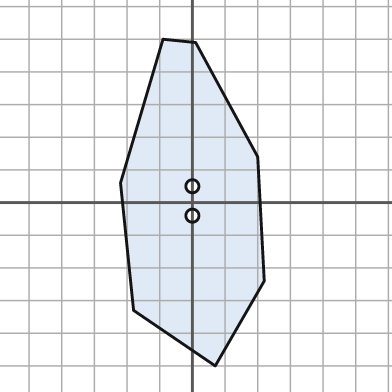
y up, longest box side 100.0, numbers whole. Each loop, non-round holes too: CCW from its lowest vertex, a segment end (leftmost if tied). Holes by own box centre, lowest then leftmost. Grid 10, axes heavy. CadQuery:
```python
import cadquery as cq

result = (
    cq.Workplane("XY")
    .moveTo(7.0, -50.0)
    .lineTo(22.0, -24.0)
    .lineTo(20.0, 14.0)
    .lineTo(1.0, 49.0)
    .lineTo(-9.0, 50.0)
    .lineTo(-22.0, 6.0)
    .lineTo(-18.0, -33.0)
    .close()
    .moveTo(0.0, -4.0)
    .circle(2.0)
    .moveTo(0.0, 5.0)
    .circle(2.0)
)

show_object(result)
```